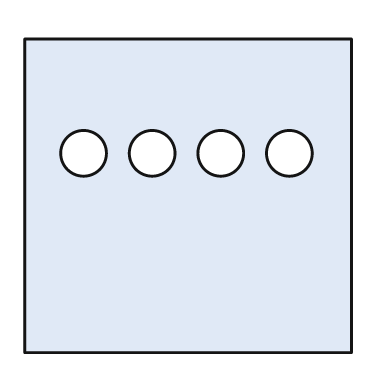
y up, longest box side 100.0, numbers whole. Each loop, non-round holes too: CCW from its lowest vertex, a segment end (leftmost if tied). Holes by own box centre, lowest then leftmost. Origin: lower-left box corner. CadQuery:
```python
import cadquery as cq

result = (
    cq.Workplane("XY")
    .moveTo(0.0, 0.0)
    .lineTo(100.0, 0.0)
    .lineTo(100.0, 96.0)
    .lineTo(0.0, 96.0)
    .close()
    .moveTo(18.0, 61.0)
    .circle(7.0)
    .moveTo(39.0, 61.0)
    .circle(7.0)
    .moveTo(60.0, 61.0)
    .circle(7.0)
    .moveTo(81.0, 61.0)
    .circle(7.0)
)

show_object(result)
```